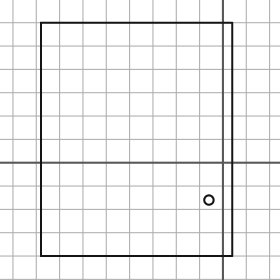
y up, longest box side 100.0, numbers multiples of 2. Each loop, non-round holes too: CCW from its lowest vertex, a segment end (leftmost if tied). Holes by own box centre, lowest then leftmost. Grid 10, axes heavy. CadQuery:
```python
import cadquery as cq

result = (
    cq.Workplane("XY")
    .moveTo(-78.0, -40.0)
    .lineTo(4.0, -40.0)
    .lineTo(4.0, 60.0)
    .lineTo(-78.0, 60.0)
    .close()
    .moveTo(-6.0, -16.0)
    .circle(2.0)
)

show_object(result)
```